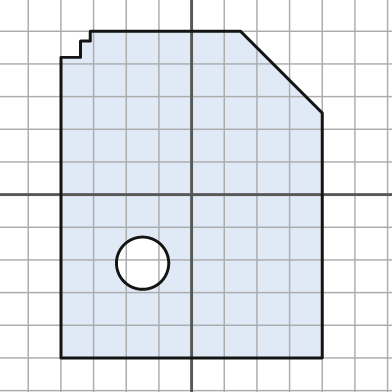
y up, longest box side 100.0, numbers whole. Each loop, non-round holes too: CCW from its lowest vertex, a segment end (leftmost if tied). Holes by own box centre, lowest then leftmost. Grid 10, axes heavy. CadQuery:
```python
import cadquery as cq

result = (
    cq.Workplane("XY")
    .moveTo(-40.0, -50.0)
    .lineTo(40.0, -50.0)
    .lineTo(40.0, 25.0)
    .lineTo(15.0, 50.0)
    .lineTo(-31.0, 50.0)
    .lineTo(-31.0, 47.0)
    .lineTo(-34.0, 47.0)
    .lineTo(-34.0, 42.0)
    .lineTo(-40.0, 42.0)
    .close()
    .moveTo(-15.0, -21.0)
    .circle(8.0)
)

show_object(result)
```